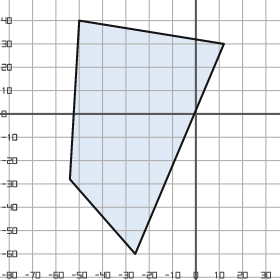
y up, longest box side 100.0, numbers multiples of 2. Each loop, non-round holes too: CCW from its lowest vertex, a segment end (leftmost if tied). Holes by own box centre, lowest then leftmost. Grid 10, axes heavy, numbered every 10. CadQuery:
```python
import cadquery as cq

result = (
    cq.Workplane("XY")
    .moveTo(-26.0, -60.0)
    .lineTo(12.0, 30.0)
    .lineTo(-50.0, 40.0)
    .lineTo(-54.0, -28.0)
    .close()
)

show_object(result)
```